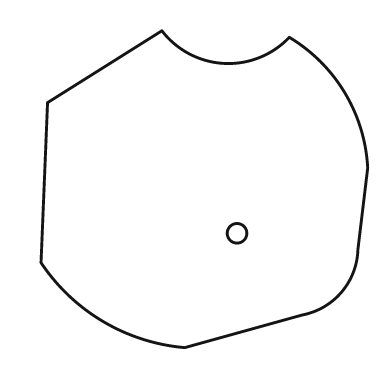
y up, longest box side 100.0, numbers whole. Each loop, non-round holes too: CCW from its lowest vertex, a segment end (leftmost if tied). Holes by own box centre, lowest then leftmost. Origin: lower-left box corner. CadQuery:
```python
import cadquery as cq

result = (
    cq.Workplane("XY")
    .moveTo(44.0, 0.0)
    .lineTo(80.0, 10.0)
    .threePointArc((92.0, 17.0), (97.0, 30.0))
    .lineTo(100.0, 55.0)
    .threePointArc((93.0, 78.0), (76.0, 95.0))
    .threePointArc((56.0, 87.0), (37.0, 97.0))
    .lineTo(2.0, 75.0)
    .lineTo(0.0, 26.0)
    .threePointArc((19.0, 8.0), (44.0, 0.0))
    .close()
    .moveTo(60.0, 35.0)
    .circle(3.0)
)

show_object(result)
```